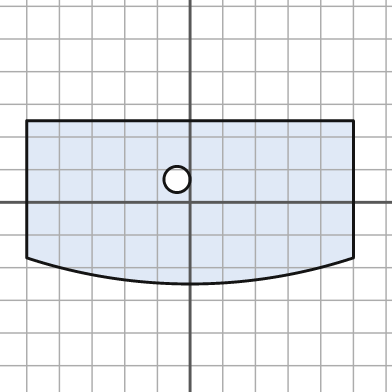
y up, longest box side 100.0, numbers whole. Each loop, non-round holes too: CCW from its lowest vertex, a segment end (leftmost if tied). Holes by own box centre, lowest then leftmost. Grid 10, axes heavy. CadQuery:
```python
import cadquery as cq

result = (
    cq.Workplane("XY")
    .moveTo(-50.0, -17.0)
    .threePointArc((0.0, -25.0), (50.0, -17.0))
    .lineTo(50.0, 25.0)
    .lineTo(-50.0, 25.0)
    .close()
    .moveTo(-4.0, 7.0)
    .circle(4.0)
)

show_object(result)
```